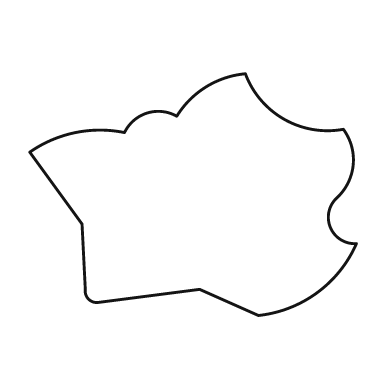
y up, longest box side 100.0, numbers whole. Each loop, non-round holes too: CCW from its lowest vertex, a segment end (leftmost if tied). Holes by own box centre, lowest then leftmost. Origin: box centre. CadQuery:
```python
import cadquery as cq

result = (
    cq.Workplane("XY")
    .moveTo(20.0, -37.0)
    .threePointArc((38.0, -30.0), (50.0, -15.0))
    .threePointArc((42.0, -10.0), (44.0, -1.0))
    .threePointArc((49.0, 9.0), (46.0, 20.0))
    .threePointArc((28.0, 23.0), (16.0, 37.0))
    .threePointArc((4.0, 33.0), (-5.0, 24.0))
    .threePointArc((-14.0, 25.0), (-21.0, 19.0))
    .threePointArc((-36.0, 19.0), (-50.0, 13.0))
    .lineTo(-34.0, -9.0)
    .lineTo(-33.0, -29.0)
    .threePointArc((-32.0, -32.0), (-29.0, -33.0))
    .lineTo(2.0, -29.0)
    .close()
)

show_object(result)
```